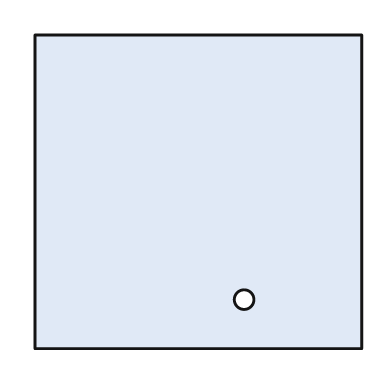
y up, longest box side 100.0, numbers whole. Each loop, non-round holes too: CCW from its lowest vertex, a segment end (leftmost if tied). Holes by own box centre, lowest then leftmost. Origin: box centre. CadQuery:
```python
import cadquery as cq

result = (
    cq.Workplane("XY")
    .moveTo(-50.0, -48.0)
    .lineTo(50.0, -48.0)
    .lineTo(50.0, 48.0)
    .lineTo(-50.0, 48.0)
    .close()
    .moveTo(14.0, -33.0)
    .circle(3.0)
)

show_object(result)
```